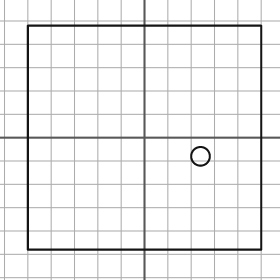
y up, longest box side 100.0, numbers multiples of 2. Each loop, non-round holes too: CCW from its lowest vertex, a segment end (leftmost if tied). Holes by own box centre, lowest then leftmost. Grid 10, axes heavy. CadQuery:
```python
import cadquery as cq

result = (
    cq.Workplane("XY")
    .moveTo(-50.0, -48.0)
    .lineTo(50.0, -48.0)
    .lineTo(50.0, 48.0)
    .lineTo(-50.0, 48.0)
    .close()
    .moveTo(24.0, -8.0)
    .circle(4.0)
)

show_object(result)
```